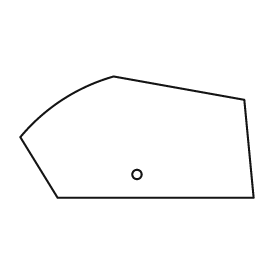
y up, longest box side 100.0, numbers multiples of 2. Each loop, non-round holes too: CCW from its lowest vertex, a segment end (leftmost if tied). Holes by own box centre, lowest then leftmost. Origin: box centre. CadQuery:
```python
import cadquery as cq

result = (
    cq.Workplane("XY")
    .moveTo(-34.0, -26.0)
    .lineTo(50.0, -26.0)
    .lineTo(46.0, 16.0)
    .lineTo(-10.0, 26.0)
    .threePointArc((-32.0, 16.0), (-50.0, 0.0))
    .close()
    .moveTo(0.0, -16.0)
    .circle(2.0)
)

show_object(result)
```